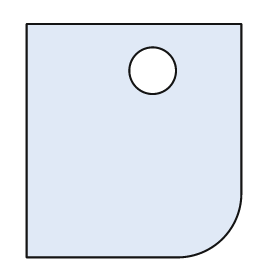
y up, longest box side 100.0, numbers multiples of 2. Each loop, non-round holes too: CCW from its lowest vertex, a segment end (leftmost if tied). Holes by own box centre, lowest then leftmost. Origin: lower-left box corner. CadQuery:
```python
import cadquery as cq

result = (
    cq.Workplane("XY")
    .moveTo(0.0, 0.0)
    .lineTo(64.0, 0.0)
    .threePointArc((84.0, 8.0), (92.0, 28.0))
    .lineTo(92.0, 100.0)
    .lineTo(0.0, 100.0)
    .close()
    .moveTo(54.0, 80.0)
    .circle(10.0)
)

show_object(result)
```